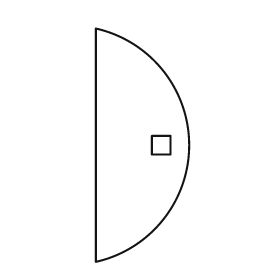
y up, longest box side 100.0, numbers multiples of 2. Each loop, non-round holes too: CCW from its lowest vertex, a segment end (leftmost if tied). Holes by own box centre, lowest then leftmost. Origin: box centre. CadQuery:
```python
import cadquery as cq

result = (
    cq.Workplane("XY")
    .moveTo(-20.0, -50.0)
    .threePointArc((20.0, 0.0), (-20.0, 50.0))
    .close()
    .moveTo(4.0, -4.0)
    .lineTo(12.0, -4.0)
    .lineTo(12.0, 4.0)
    .lineTo(4.0, 4.0)
    .close()
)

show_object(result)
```